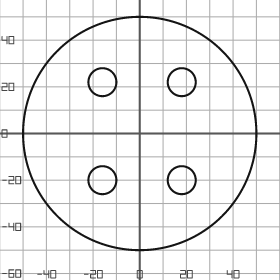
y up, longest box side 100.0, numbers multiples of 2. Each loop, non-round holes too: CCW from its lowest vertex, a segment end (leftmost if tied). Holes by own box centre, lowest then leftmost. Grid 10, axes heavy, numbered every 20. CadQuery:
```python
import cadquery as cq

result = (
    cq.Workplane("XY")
    .moveTo(0.0, 0.0)
    .circle(50.0)
    .moveTo(-16.0, -20.0)
    .circle(6.0)
    .moveTo(18.0, -20.0)
    .circle(6.0)
    .moveTo(-16.0, 22.0)
    .circle(6.0)
    .moveTo(18.0, 22.0)
    .circle(6.0)
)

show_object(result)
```